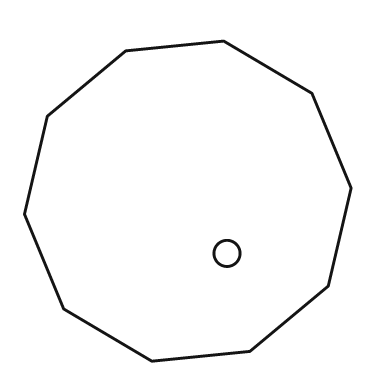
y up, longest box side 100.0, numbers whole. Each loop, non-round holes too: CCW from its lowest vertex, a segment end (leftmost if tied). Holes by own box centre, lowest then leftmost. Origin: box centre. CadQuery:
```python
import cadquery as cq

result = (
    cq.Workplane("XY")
    .moveTo(-11.0, -49.0)
    .lineTo(19.0, -46.0)
    .lineTo(43.0, -26.0)
    .lineTo(50.0, 4.0)
    .lineTo(38.0, 33.0)
    .lineTo(11.0, 49.0)
    .lineTo(-19.0, 46.0)
    .lineTo(-43.0, 26.0)
    .lineTo(-50.0, -4.0)
    .lineTo(-38.0, -33.0)
    .close()
    .moveTo(12.0, -16.0)
    .circle(4.0)
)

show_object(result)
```